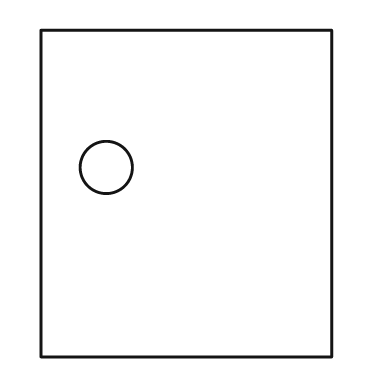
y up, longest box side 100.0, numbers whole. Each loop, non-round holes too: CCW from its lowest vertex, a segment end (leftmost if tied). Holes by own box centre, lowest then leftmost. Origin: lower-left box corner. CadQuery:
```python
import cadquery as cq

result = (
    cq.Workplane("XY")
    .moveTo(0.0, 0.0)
    .lineTo(89.0, 0.0)
    .lineTo(89.0, 100.0)
    .lineTo(0.0, 100.0)
    .close()
    .moveTo(20.0, 58.0)
    .circle(8.0)
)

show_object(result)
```